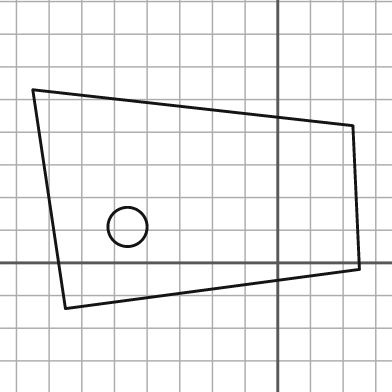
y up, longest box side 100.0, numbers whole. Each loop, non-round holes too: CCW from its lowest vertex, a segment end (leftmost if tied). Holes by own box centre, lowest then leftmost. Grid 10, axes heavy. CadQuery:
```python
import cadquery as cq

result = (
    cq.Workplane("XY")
    .moveTo(-65.0, -14.0)
    .lineTo(25.0, -2.0)
    .lineTo(23.0, 42.0)
    .lineTo(-75.0, 53.0)
    .close()
    .moveTo(-46.0, 11.0)
    .circle(6.0)
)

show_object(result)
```